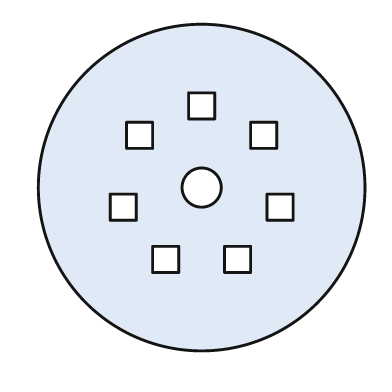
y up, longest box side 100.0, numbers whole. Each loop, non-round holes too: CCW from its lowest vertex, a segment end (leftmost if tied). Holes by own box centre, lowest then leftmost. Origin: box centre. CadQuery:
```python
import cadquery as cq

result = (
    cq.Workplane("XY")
    .moveTo(0.0, 0.0)
    .circle(50.0)
    .moveTo(-15.0, -26.0)
    .lineTo(-7.0, -26.0)
    .lineTo(-7.0, -18.0)
    .lineTo(-15.0, -18.0)
    .close()
    .moveTo(7.0, -26.0)
    .lineTo(15.0, -26.0)
    .lineTo(15.0, -18.0)
    .lineTo(7.0, -18.0)
    .close()
    .moveTo(-28.0, -10.0)
    .lineTo(-20.0, -10.0)
    .lineTo(-20.0, -2.0)
    .lineTo(-28.0, -2.0)
    .close()
    .moveTo(20.0, -10.0)
    .lineTo(28.0, -10.0)
    .lineTo(28.0, -2.0)
    .lineTo(20.0, -2.0)
    .close()
    .moveTo(0.0, 0.0)
    .circle(6.0)
    .moveTo(-23.0, 12.0)
    .lineTo(-15.0, 12.0)
    .lineTo(-15.0, 20.0)
    .lineTo(-23.0, 20.0)
    .close()
    .moveTo(15.0, 12.0)
    .lineTo(23.0, 12.0)
    .lineTo(23.0, 20.0)
    .lineTo(15.0, 20.0)
    .close()
    .moveTo(-4.0, 21.0)
    .lineTo(4.0, 21.0)
    .lineTo(4.0, 29.0)
    .lineTo(-4.0, 29.0)
    .close()
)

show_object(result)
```